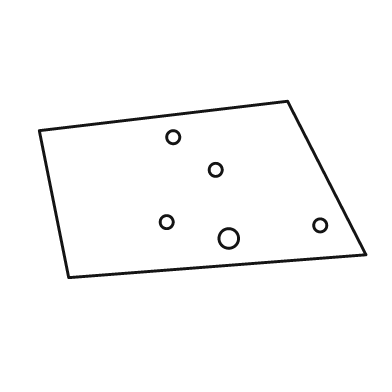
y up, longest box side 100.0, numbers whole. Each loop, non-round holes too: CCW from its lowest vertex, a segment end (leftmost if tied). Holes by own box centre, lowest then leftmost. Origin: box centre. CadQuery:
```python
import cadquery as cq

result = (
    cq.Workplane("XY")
    .moveTo(-41.0, -27.0)
    .lineTo(50.0, -20.0)
    .lineTo(26.0, 27.0)
    .lineTo(-50.0, 18.0)
    .close()
    .moveTo(8.0, -15.0)
    .circle(3.0)
    .moveTo(36.0, -11.0)
    .circle(2.0)
    .moveTo(-11.0, -10.0)
    .circle(2.0)
    .moveTo(4.0, 6.0)
    .circle(2.0)
    .moveTo(-9.0, 16.0)
    .circle(2.0)
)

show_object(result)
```